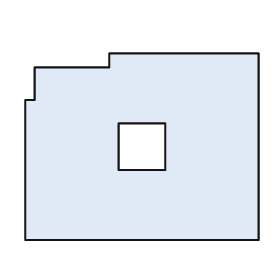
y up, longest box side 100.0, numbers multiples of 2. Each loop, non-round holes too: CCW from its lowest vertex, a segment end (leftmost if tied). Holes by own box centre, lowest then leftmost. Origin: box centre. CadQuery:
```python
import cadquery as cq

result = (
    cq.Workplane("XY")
    .moveTo(-50.0, -40.0)
    .lineTo(50.0, -40.0)
    .lineTo(50.0, 40.0)
    .lineTo(-14.0, 40.0)
    .lineTo(-14.0, 34.0)
    .lineTo(-46.0, 34.0)
    .lineTo(-46.0, 20.0)
    .lineTo(-50.0, 20.0)
    .close()
    .moveTo(-10.0, -10.0)
    .lineTo(10.0, -10.0)
    .lineTo(10.0, 10.0)
    .lineTo(-10.0, 10.0)
    .close()
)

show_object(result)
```